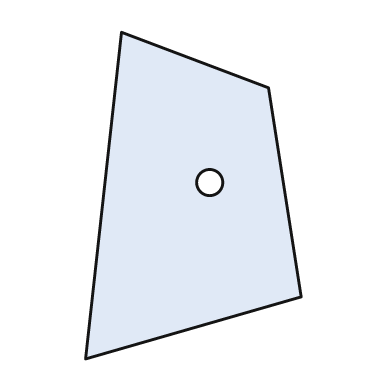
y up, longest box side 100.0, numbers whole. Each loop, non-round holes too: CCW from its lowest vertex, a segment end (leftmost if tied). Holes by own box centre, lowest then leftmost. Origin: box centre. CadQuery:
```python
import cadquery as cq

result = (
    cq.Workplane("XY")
    .moveTo(-33.0, -50.0)
    .lineTo(33.0, -31.0)
    .lineTo(23.0, 33.0)
    .lineTo(-22.0, 50.0)
    .close()
    .moveTo(5.0, 4.0)
    .circle(4.0)
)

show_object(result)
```